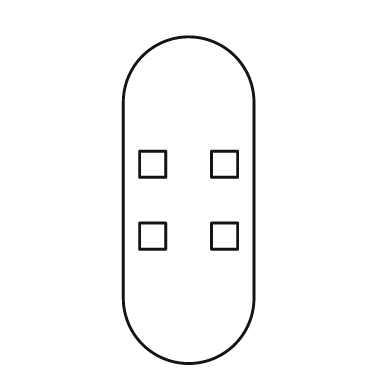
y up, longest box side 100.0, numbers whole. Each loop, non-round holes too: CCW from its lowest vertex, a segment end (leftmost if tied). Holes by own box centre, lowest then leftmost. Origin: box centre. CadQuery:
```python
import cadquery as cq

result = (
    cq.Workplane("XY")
    .moveTo(-20.0, -30.0)
    .threePointArc((0.0, -50.0), (20.0, -30.0))
    .lineTo(20.0, 30.0)
    .threePointArc((0.0, 50.0), (-20.0, 30.0))
    .close()
    .moveTo(-15.0, -15.0)
    .lineTo(-7.0, -15.0)
    .lineTo(-7.0, -7.0)
    .lineTo(-15.0, -7.0)
    .close()
    .moveTo(7.0, -15.0)
    .lineTo(15.0, -15.0)
    .lineTo(15.0, -7.0)
    .lineTo(7.0, -7.0)
    .close()
    .moveTo(-15.0, 7.0)
    .lineTo(-7.0, 7.0)
    .lineTo(-7.0, 15.0)
    .lineTo(-15.0, 15.0)
    .close()
    .moveTo(7.0, 7.0)
    .lineTo(15.0, 7.0)
    .lineTo(15.0, 15.0)
    .lineTo(7.0, 15.0)
    .close()
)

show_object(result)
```